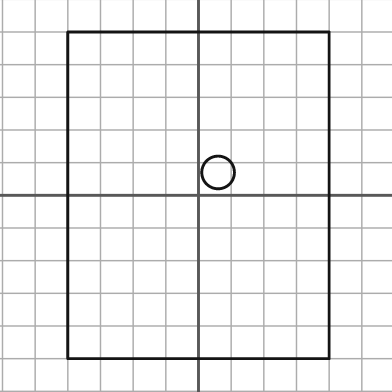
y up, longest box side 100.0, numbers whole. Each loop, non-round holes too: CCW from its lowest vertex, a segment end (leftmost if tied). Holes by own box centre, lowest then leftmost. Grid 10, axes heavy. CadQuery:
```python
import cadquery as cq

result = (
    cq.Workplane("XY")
    .moveTo(-40.0, -50.0)
    .lineTo(40.0, -50.0)
    .lineTo(40.0, 50.0)
    .lineTo(-40.0, 50.0)
    .close()
    .moveTo(6.0, 7.0)
    .circle(5.0)
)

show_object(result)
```